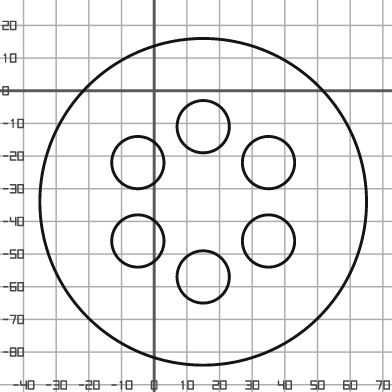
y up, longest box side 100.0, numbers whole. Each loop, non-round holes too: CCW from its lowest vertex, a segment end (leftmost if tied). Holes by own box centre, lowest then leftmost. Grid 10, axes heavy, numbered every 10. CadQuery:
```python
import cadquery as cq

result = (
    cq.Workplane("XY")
    .moveTo(15.0, -34.0)
    .circle(50.0)
    .moveTo(15.0, -57.0)
    .circle(8.0)
    .moveTo(-5.0, -46.0)
    .circle(8.0)
    .moveTo(35.0, -46.0)
    .circle(8.0)
    .moveTo(-5.0, -22.0)
    .circle(8.0)
    .moveTo(35.0, -22.0)
    .circle(8.0)
    .moveTo(15.0, -11.0)
    .circle(8.0)
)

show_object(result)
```